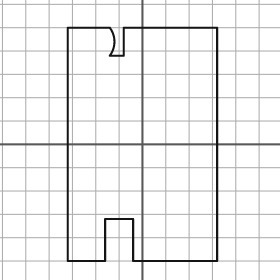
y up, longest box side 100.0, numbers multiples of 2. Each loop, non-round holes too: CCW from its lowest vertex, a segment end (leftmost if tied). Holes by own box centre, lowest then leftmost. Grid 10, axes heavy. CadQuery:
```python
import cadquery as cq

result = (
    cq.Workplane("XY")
    .moveTo(-32.0, -50.0)
    .lineTo(-16.0, -50.0)
    .lineTo(-16.0, -32.0)
    .lineTo(-4.0, -32.0)
    .lineTo(-4.0, -50.0)
    .lineTo(32.0, -50.0)
    .lineTo(32.0, 50.0)
    .lineTo(-8.0, 50.0)
    .lineTo(-8.0, 38.0)
    .lineTo(-14.0, 38.0)
    .threePointArc((-12.0, 44.0), (-14.0, 50.0))
    .lineTo(-32.0, 50.0)
    .close()
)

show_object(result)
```